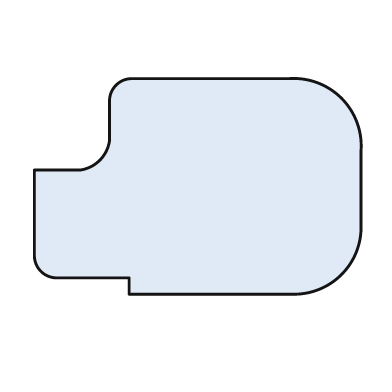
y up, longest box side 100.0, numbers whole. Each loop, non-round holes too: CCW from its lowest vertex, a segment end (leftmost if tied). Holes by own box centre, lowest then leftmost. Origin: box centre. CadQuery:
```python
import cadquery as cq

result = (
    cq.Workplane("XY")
    .moveTo(-21.0, -33.0)
    .lineTo(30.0, -33.0)
    .threePointArc((44.0, -27.0), (50.0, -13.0))
    .lineTo(50.0, 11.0)
    .threePointArc((44.0, 27.0), (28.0, 33.0))
    .lineTo(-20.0, 33.0)
    .threePointArc((-25.0, 31.0), (-27.0, 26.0))
    .lineTo(-27.0, 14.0)
    .threePointArc((-30.0, 8.0), (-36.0, 5.0))
    .lineTo(-50.0, 5.0)
    .lineTo(-50.0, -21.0)
    .threePointArc((-48.0, -26.0), (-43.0, -28.0))
    .lineTo(-21.0, -28.0)
    .close()
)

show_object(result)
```